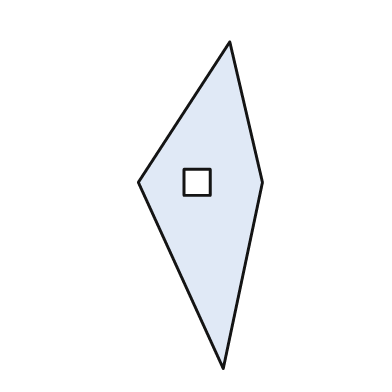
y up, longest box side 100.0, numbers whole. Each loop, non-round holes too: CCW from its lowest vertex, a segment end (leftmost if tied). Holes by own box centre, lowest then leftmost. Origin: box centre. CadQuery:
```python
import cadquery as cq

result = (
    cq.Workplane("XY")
    .moveTo(7.0, -50.0)
    .lineTo(19.0, 7.0)
    .lineTo(9.0, 50.0)
    .lineTo(-19.0, 7.0)
    .close()
    .moveTo(-5.0, 3.0)
    .lineTo(3.0, 3.0)
    .lineTo(3.0, 11.0)
    .lineTo(-5.0, 11.0)
    .close()
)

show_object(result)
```